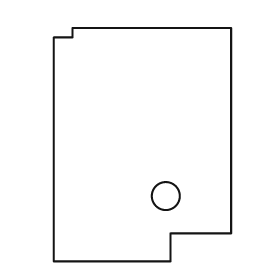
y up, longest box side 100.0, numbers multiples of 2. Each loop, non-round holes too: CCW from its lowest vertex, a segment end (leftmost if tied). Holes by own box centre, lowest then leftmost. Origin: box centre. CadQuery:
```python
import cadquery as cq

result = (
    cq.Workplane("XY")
    .moveTo(-38.0, -50.0)
    .lineTo(12.0, -50.0)
    .lineTo(12.0, -38.0)
    .lineTo(38.0, -38.0)
    .lineTo(38.0, 50.0)
    .lineTo(-30.0, 50.0)
    .lineTo(-30.0, 46.0)
    .lineTo(-38.0, 46.0)
    .close()
    .moveTo(10.0, -22.0)
    .circle(6.0)
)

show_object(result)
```